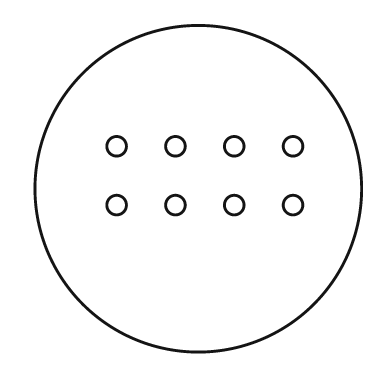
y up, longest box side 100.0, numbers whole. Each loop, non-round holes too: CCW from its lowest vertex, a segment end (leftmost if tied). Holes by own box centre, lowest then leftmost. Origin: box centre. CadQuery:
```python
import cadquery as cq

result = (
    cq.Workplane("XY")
    .moveTo(0.0, 0.0)
    .circle(50.0)
    .moveTo(-25.0, -5.0)
    .circle(3.0)
    .moveTo(-7.0, -5.0)
    .circle(3.0)
    .moveTo(11.0, -5.0)
    .circle(3.0)
    .moveTo(29.0, -5.0)
    .circle(3.0)
    .moveTo(-25.0, 13.0)
    .circle(3.0)
    .moveTo(-7.0, 13.0)
    .circle(3.0)
    .moveTo(11.0, 13.0)
    .circle(3.0)
    .moveTo(29.0, 13.0)
    .circle(3.0)
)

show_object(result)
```